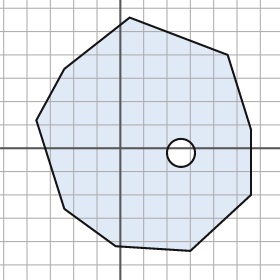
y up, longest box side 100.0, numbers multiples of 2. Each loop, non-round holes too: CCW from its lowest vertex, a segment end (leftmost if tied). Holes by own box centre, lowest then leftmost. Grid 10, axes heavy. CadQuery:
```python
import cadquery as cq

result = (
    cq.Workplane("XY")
    .moveTo(30.0, -44.0)
    .lineTo(56.0, -20.0)
    .lineTo(56.0, 8.0)
    .lineTo(46.0, 40.0)
    .lineTo(4.0, 56.0)
    .lineTo(-24.0, 34.0)
    .lineTo(-36.0, 12.0)
    .lineTo(-24.0, -26.0)
    .lineTo(-2.0, -42.0)
    .close()
    .moveTo(26.0, -2.0)
    .circle(6.0)
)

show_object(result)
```